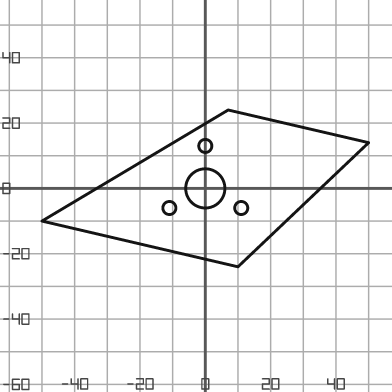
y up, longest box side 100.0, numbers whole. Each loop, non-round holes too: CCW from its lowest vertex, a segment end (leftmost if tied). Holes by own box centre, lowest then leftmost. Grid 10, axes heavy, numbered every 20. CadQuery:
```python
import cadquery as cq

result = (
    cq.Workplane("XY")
    .moveTo(10.0, -24.0)
    .lineTo(50.0, 14.0)
    .lineTo(7.0, 24.0)
    .lineTo(-50.0, -10.0)
    .close()
    .moveTo(-11.0, -6.0)
    .circle(2.0)
    .moveTo(11.0, -6.0)
    .circle(2.0)
    .moveTo(0.0, 0.0)
    .circle(6.0)
    .moveTo(0.0, 13.0)
    .circle(2.0)
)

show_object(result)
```